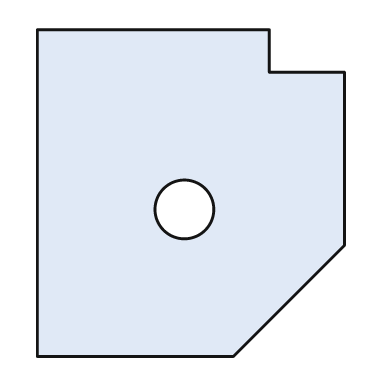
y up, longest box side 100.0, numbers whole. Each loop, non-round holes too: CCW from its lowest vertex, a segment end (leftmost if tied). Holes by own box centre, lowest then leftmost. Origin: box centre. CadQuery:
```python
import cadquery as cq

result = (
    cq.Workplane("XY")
    .moveTo(-47.0, -50.0)
    .lineTo(13.0, -50.0)
    .lineTo(47.0, -16.0)
    .lineTo(47.0, 37.0)
    .lineTo(24.0, 37.0)
    .lineTo(24.0, 50.0)
    .lineTo(-47.0, 50.0)
    .close()
    .moveTo(-2.0, -5.0)
    .circle(9.0)
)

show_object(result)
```